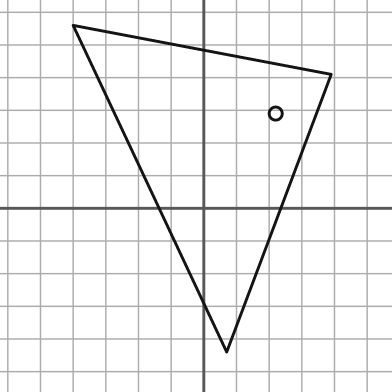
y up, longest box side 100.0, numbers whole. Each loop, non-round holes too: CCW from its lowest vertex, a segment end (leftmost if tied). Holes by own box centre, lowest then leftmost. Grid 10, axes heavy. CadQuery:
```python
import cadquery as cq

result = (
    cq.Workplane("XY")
    .moveTo(7.0, -44.0)
    .lineTo(39.0, 41.0)
    .lineTo(-40.0, 56.0)
    .close()
    .moveTo(22.0, 29.0)
    .circle(2.0)
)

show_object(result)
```